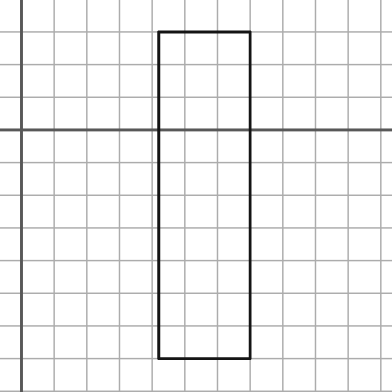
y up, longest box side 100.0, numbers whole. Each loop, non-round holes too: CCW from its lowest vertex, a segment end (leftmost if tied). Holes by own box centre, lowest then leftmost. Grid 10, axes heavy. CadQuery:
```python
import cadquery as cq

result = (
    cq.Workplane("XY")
    .moveTo(42.0, -70.0)
    .lineTo(70.0, -70.0)
    .lineTo(70.0, 30.0)
    .lineTo(42.0, 30.0)
    .close()
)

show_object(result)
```